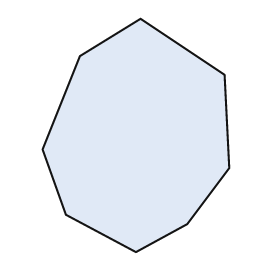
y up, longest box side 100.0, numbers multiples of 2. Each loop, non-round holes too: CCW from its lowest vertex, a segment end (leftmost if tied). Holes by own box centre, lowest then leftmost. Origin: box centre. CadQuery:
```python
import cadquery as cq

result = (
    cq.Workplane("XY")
    .moveTo(0.0, -50.0)
    .lineTo(22.0, -38.0)
    .lineTo(40.0, -14.0)
    .lineTo(38.0, 26.0)
    .lineTo(2.0, 50.0)
    .lineTo(-24.0, 34.0)
    .lineTo(-40.0, -6.0)
    .lineTo(-30.0, -34.0)
    .close()
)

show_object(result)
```